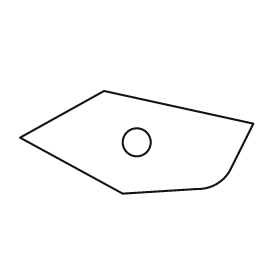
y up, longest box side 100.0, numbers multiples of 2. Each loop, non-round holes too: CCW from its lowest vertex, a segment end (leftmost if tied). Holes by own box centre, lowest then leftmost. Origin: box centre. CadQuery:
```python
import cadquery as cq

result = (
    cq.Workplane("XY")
    .moveTo(-6.0, -22.0)
    .lineTo(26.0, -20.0)
    .threePointArc((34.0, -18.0), (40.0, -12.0))
    .lineTo(50.0, 8.0)
    .lineTo(-14.0, 22.0)
    .lineTo(-50.0, 2.0)
    .close()
    .moveTo(0.0, 0.0)
    .circle(6.0)
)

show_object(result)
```